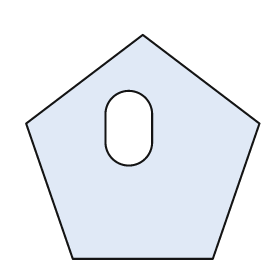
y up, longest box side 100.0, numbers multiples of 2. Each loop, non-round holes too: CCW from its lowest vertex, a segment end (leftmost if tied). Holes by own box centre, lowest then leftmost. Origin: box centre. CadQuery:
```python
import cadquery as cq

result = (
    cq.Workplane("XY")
    .moveTo(-30.0, -48.0)
    .lineTo(30.0, -48.0)
    .lineTo(50.0, 10.0)
    .lineTo(0.0, 48.0)
    .lineTo(-50.0, 10.0)
    .close()
    .moveTo(-16.0, 2.0)
    .threePointArc((-6.0, -8.0), (4.0, 2.0))
    .lineTo(4.0, 14.0)
    .threePointArc((-6.0, 24.0), (-16.0, 14.0))
    .close()
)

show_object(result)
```